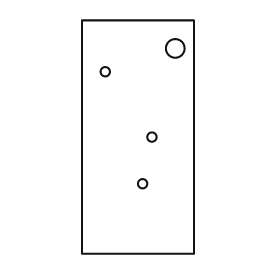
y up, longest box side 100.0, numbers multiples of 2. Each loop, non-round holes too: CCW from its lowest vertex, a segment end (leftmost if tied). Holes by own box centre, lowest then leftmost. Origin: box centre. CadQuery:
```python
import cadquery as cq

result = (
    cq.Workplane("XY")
    .moveTo(-24.0, -50.0)
    .lineTo(24.0, -50.0)
    .lineTo(24.0, 50.0)
    .lineTo(-24.0, 50.0)
    .close()
    .moveTo(2.0, -20.0)
    .circle(2.0)
    .moveTo(6.0, 0.0)
    .circle(2.0)
    .moveTo(-14.0, 28.0)
    .circle(2.0)
    .moveTo(16.0, 38.0)
    .circle(4.0)
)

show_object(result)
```